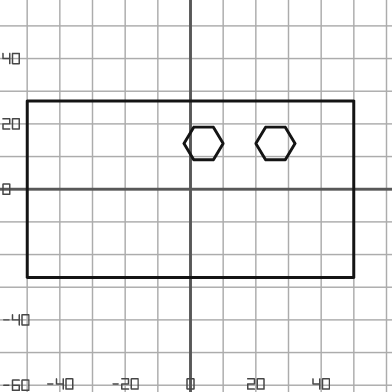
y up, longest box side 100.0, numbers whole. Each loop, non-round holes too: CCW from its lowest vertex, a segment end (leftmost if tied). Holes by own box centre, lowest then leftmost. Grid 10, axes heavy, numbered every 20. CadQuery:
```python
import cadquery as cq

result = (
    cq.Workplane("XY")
    .moveTo(-50.0, -27.0)
    .lineTo(50.0, -27.0)
    .lineTo(50.0, 27.0)
    .lineTo(-50.0, 27.0)
    .close()
    .moveTo(1.0, 9.0)
    .lineTo(7.0, 9.0)
    .lineTo(10.0, 14.0)
    .lineTo(7.0, 19.0)
    .lineTo(1.0, 19.0)
    .lineTo(-2.0, 14.0)
    .close()
    .moveTo(23.0, 9.0)
    .lineTo(29.0, 9.0)
    .lineTo(32.0, 14.0)
    .lineTo(29.0, 19.0)
    .lineTo(23.0, 19.0)
    .lineTo(20.0, 14.0)
    .close()
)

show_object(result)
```